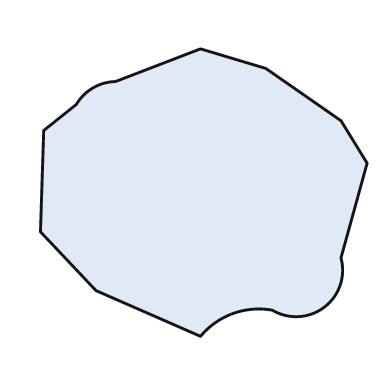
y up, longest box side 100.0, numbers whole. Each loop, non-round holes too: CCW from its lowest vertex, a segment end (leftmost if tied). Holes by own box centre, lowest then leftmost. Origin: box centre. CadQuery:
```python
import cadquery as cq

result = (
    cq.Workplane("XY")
    .moveTo(-1.0, -44.0)
    .threePointArc((9.0, -37.0), (21.0, -36.0))
    .threePointArc((37.0, -35.0), (42.0, -20.0))
    .lineTo(50.0, 9.0)
    .lineTo(42.0, 22.0)
    .lineTo(19.0, 38.0)
    .lineTo(-1.0, 44.0)
    .lineTo(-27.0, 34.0)
    .threePointArc((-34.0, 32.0), (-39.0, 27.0))
    .lineTo(-49.0, 19.0)
    .lineTo(-50.0, -12.0)
    .lineTo(-33.0, -30.0)
    .close()
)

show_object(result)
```